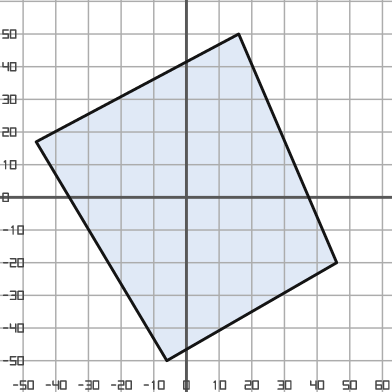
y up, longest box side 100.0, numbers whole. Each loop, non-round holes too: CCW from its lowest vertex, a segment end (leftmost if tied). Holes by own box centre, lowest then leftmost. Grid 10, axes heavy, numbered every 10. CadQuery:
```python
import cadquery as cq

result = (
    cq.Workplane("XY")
    .moveTo(-6.0, -50.0)
    .lineTo(46.0, -20.0)
    .lineTo(16.0, 50.0)
    .lineTo(-46.0, 17.0)
    .close()
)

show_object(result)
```